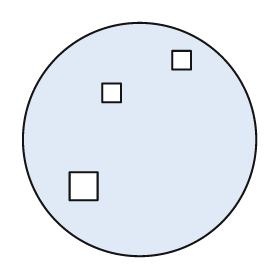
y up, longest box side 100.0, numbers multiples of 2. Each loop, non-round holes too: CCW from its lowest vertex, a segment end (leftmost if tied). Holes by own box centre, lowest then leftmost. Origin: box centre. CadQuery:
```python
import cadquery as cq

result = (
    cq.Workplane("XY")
    .moveTo(0.0, 0.0)
    .circle(50.0)
    .moveTo(-30.0, -26.0)
    .lineTo(-18.0, -26.0)
    .lineTo(-18.0, -14.0)
    .lineTo(-30.0, -14.0)
    .close()
    .moveTo(-16.0, 16.0)
    .lineTo(-8.0, 16.0)
    .lineTo(-8.0, 24.0)
    .lineTo(-16.0, 24.0)
    .close()
    .moveTo(14.0, 30.0)
    .lineTo(22.0, 30.0)
    .lineTo(22.0, 38.0)
    .lineTo(14.0, 38.0)
    .close()
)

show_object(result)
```